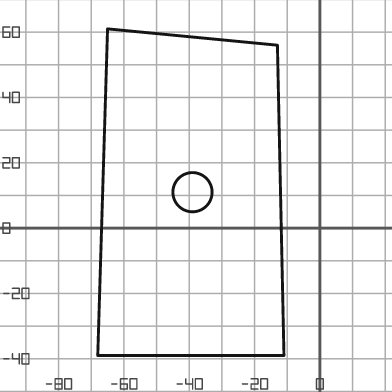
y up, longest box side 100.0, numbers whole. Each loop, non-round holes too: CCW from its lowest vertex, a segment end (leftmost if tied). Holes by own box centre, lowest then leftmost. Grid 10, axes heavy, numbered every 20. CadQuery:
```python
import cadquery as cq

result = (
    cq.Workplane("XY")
    .moveTo(-68.0, -39.0)
    .lineTo(-11.0, -39.0)
    .lineTo(-13.0, 56.0)
    .lineTo(-65.0, 61.0)
    .close()
    .moveTo(-39.0, 11.0)
    .circle(6.0)
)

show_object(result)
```